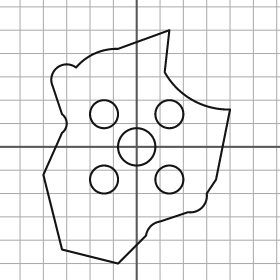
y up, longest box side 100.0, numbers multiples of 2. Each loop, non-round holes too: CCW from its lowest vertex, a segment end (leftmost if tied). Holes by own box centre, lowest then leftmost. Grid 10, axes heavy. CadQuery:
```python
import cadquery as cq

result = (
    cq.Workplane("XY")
    .moveTo(-8.0, -50.0)
    .lineTo(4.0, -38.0)
    .threePointArc((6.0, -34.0), (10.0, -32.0))
    .lineTo(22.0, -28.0)
    .threePointArc((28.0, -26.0), (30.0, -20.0))
    .lineTo(34.0, -14.0)
    .lineTo(40.0, 16.0)
    .threePointArc((24.0, 20.0), (12.0, 32.0))
    .lineTo(14.0, 50.0)
    .lineTo(-8.0, 42.0)
    .threePointArc((-18.0, 40.0), (-26.0, 34.0))
    .threePointArc((-34.0, 34.0), (-36.0, 26.0))
    .lineTo(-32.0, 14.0)
    .threePointArc((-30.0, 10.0), (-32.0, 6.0))
    .lineTo(-40.0, -12.0)
    .lineTo(-32.0, -44.0)
    .close()
    .moveTo(-14.0, -14.0)
    .circle(6.0)
    .moveTo(14.0, -14.0)
    .circle(6.0)
    .moveTo(0.0, 0.0)
    .circle(8.0)
    .moveTo(-14.0, 14.0)
    .circle(6.0)
    .moveTo(14.0, 14.0)
    .circle(6.0)
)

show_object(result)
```